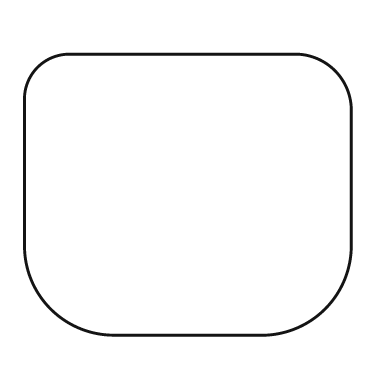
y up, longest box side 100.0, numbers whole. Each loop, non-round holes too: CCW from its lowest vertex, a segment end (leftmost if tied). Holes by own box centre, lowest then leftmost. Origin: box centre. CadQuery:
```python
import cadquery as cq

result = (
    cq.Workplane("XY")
    .moveTo(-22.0, -43.0)
    .lineTo(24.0, -43.0)
    .threePointArc((42.0, -35.0), (50.0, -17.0))
    .lineTo(50.0, 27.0)
    .threePointArc((45.0, 38.0), (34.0, 43.0))
    .lineTo(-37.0, 43.0)
    .threePointArc((-46.0, 39.0), (-50.0, 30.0))
    .lineTo(-50.0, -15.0)
    .threePointArc((-42.0, -35.0), (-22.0, -43.0))
    .close()
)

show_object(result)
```